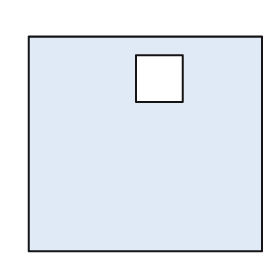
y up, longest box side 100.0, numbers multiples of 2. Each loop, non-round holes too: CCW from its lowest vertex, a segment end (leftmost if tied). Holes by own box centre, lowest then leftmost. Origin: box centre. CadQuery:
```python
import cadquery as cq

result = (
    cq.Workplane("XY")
    .moveTo(-50.0, -46.0)
    .lineTo(50.0, -46.0)
    .lineTo(50.0, 46.0)
    .lineTo(-50.0, 46.0)
    .close()
    .moveTo(-4.0, 18.0)
    .lineTo(16.0, 18.0)
    .lineTo(16.0, 38.0)
    .lineTo(-4.0, 38.0)
    .close()
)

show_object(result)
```